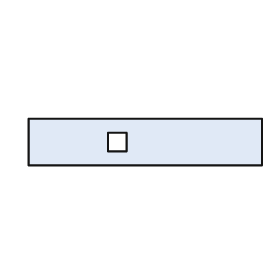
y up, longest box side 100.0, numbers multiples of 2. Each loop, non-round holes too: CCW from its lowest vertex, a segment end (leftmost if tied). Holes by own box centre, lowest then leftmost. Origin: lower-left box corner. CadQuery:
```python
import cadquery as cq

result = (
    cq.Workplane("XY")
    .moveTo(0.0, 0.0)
    .lineTo(100.0, 0.0)
    .lineTo(100.0, 20.0)
    .lineTo(0.0, 20.0)
    .close()
    .moveTo(34.0, 6.0)
    .lineTo(42.0, 6.0)
    .lineTo(42.0, 14.0)
    .lineTo(34.0, 14.0)
    .close()
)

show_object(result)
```